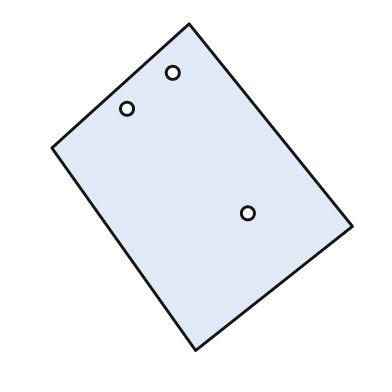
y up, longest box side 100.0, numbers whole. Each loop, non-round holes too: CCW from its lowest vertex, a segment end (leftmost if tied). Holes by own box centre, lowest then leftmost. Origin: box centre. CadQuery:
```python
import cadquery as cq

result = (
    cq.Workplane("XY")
    .moveTo(-2.0, -50.0)
    .lineTo(46.0, -12.0)
    .lineTo(-4.0, 50.0)
    .lineTo(-46.0, 12.0)
    .close()
    .moveTo(14.0, -8.0)
    .circle(2.0)
    .moveTo(-23.0, 24.0)
    .circle(2.0)
    .moveTo(-9.0, 35.0)
    .circle(2.0)
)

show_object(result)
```